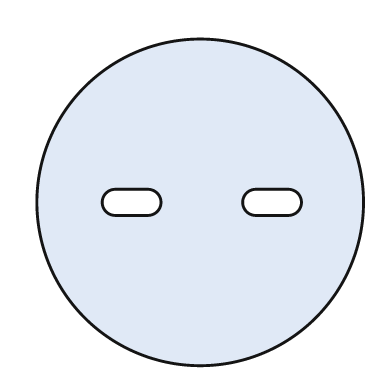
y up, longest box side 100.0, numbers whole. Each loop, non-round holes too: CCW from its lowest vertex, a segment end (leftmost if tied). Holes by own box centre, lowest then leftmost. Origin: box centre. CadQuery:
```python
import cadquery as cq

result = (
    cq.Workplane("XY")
    .moveTo(0.0, 0.0)
    .circle(50.0)
    .moveTo(-26.0, -4.0)
    .lineTo(-16.0, -4.0)
    .threePointArc((-12.0, 0.0), (-16.0, 4.0))
    .lineTo(-26.0, 4.0)
    .threePointArc((-30.0, 0.0), (-26.0, -4.0))
    .close()
    .moveTo(17.0, -4.0)
    .lineTo(27.0, -4.0)
    .threePointArc((31.0, 0.0), (27.0, 4.0))
    .lineTo(17.0, 4.0)
    .threePointArc((13.0, 0.0), (17.0, -4.0))
    .close()
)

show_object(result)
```